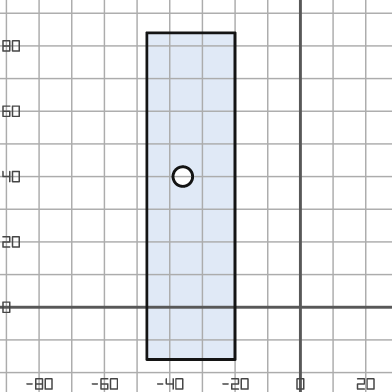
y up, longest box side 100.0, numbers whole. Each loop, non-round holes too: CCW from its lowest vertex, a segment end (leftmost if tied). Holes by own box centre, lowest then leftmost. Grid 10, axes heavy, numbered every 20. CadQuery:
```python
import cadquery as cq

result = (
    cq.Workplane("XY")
    .moveTo(-47.0, -16.0)
    .lineTo(-20.0, -16.0)
    .lineTo(-20.0, 84.0)
    .lineTo(-47.0, 84.0)
    .close()
    .moveTo(-36.0, 40.0)
    .circle(3.0)
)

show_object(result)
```